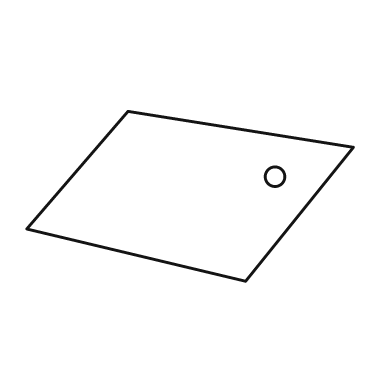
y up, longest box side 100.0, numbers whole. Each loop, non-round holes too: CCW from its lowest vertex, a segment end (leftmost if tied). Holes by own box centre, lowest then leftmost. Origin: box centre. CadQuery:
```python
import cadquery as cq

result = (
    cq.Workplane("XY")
    .moveTo(17.0, -26.0)
    .lineTo(50.0, 15.0)
    .lineTo(-19.0, 26.0)
    .lineTo(-50.0, -10.0)
    .close()
    .moveTo(26.0, 6.0)
    .circle(3.0)
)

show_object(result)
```